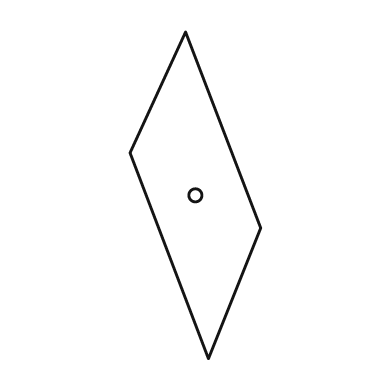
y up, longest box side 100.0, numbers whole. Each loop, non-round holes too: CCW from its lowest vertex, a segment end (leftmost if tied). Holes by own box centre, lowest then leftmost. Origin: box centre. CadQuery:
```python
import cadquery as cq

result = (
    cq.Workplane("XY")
    .moveTo(4.0, -50.0)
    .lineTo(20.0, -10.0)
    .lineTo(-3.0, 50.0)
    .lineTo(-20.0, 13.0)
    .close()
    .moveTo(0.0, 0.0)
    .circle(2.0)
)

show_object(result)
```